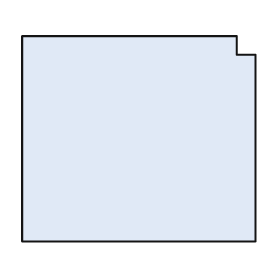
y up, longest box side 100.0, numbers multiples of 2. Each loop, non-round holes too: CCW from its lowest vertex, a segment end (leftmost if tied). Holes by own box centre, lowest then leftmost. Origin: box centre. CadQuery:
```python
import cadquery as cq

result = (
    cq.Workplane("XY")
    .moveTo(-50.0, -44.0)
    .lineTo(50.0, -44.0)
    .lineTo(50.0, 36.0)
    .lineTo(42.0, 36.0)
    .lineTo(42.0, 44.0)
    .lineTo(-50.0, 44.0)
    .close()
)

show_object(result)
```